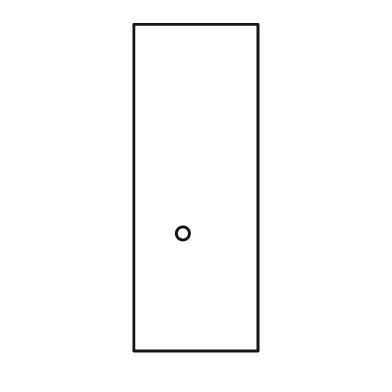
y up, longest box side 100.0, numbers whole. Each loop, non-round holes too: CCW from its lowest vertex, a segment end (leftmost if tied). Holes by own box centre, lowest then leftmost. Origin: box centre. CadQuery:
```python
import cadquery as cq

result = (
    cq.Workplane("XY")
    .moveTo(-19.0, -50.0)
    .lineTo(19.0, -50.0)
    .lineTo(19.0, 50.0)
    .lineTo(-19.0, 50.0)
    .close()
    .moveTo(-4.0, -14.0)
    .circle(2.0)
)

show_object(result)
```